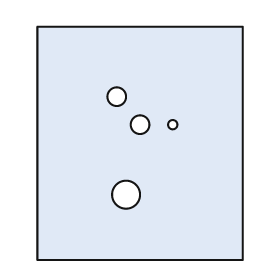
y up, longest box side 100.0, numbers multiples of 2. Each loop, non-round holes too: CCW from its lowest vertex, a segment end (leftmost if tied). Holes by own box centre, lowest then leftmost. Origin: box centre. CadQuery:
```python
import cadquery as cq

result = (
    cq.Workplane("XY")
    .moveTo(-44.0, -50.0)
    .lineTo(44.0, -50.0)
    .lineTo(44.0, 50.0)
    .lineTo(-44.0, 50.0)
    .close()
    .moveTo(-6.0, -22.0)
    .circle(6.0)
    .moveTo(0.0, 8.0)
    .circle(4.0)
    .moveTo(14.0, 8.0)
    .circle(2.0)
    .moveTo(-10.0, 20.0)
    .circle(4.0)
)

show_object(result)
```